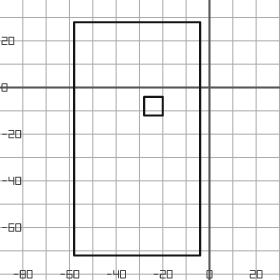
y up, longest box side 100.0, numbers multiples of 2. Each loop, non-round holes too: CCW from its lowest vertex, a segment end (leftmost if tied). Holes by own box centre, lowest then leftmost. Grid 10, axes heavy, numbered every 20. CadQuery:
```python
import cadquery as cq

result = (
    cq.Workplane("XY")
    .moveTo(-58.0, -72.0)
    .lineTo(-4.0, -72.0)
    .lineTo(-4.0, 28.0)
    .lineTo(-58.0, 28.0)
    .close()
    .moveTo(-28.0, -12.0)
    .lineTo(-20.0, -12.0)
    .lineTo(-20.0, -4.0)
    .lineTo(-28.0, -4.0)
    .close()
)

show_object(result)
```